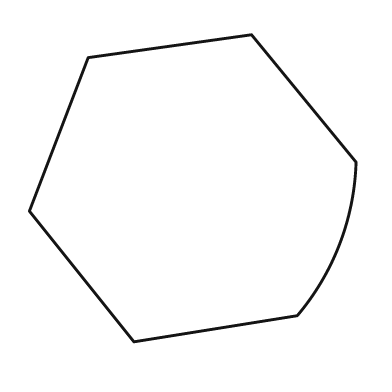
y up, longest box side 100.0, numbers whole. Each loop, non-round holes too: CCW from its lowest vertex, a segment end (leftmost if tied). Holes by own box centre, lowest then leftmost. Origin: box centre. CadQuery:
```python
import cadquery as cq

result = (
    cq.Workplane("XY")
    .moveTo(-18.0, -47.0)
    .lineTo(32.0, -39.0)
    .threePointArc((45.0, -17.0), (50.0, 8.0))
    .lineTo(18.0, 47.0)
    .lineTo(-32.0, 40.0)
    .lineTo(-50.0, -7.0)
    .close()
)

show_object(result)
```